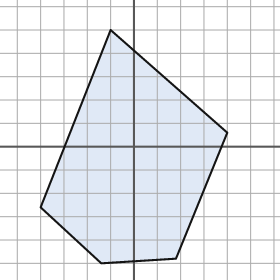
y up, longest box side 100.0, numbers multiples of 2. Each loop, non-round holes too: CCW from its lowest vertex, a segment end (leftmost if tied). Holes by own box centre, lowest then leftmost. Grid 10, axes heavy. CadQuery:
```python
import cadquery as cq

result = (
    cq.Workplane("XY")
    .moveTo(-14.0, -50.0)
    .lineTo(18.0, -48.0)
    .lineTo(40.0, 6.0)
    .lineTo(-10.0, 50.0)
    .lineTo(-40.0, -26.0)
    .close()
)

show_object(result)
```